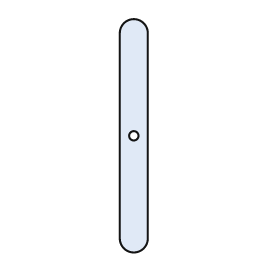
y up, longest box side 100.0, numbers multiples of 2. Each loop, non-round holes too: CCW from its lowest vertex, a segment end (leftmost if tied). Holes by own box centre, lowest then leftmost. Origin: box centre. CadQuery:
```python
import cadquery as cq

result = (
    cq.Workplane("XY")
    .moveTo(-6.0, -44.0)
    .threePointArc((0.0, -50.0), (6.0, -44.0))
    .lineTo(6.0, 44.0)
    .threePointArc((0.0, 50.0), (-6.0, 44.0))
    .close()
    .moveTo(0.0, 0.0)
    .circle(2.0)
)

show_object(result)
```